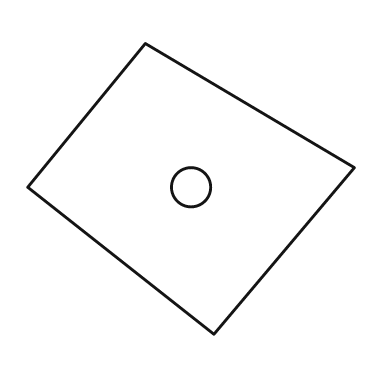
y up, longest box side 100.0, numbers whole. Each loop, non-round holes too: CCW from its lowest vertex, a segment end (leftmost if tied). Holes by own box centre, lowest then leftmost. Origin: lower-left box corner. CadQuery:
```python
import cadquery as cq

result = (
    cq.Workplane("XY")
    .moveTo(57.0, 0.0)
    .lineTo(100.0, 51.0)
    .lineTo(36.0, 89.0)
    .lineTo(0.0, 45.0)
    .close()
    .moveTo(50.0, 45.0)
    .circle(6.0)
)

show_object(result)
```